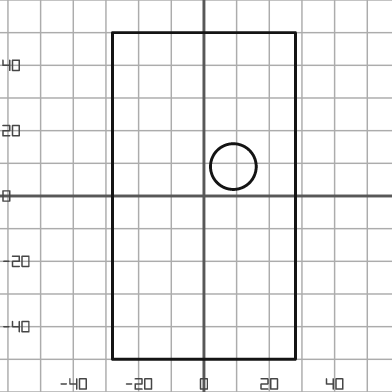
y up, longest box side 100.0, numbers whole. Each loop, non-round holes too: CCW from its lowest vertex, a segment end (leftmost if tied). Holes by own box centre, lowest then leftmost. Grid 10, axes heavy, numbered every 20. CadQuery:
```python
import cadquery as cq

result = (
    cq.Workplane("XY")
    .moveTo(-28.0, -50.0)
    .lineTo(28.0, -50.0)
    .lineTo(28.0, 50.0)
    .lineTo(-28.0, 50.0)
    .close()
    .moveTo(9.0, 9.0)
    .circle(7.0)
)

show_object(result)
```